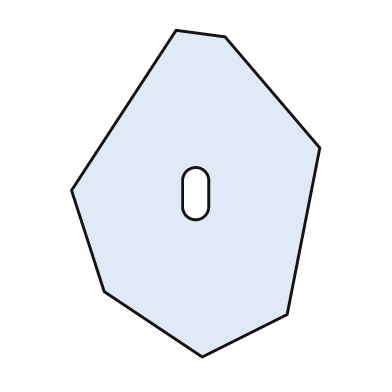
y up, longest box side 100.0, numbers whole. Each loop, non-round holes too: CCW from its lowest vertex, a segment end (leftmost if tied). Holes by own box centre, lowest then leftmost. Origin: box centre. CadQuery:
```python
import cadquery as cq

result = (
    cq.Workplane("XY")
    .moveTo(2.0, -50.0)
    .lineTo(28.0, -37.0)
    .lineTo(38.0, 14.0)
    .lineTo(9.0, 48.0)
    .lineTo(-6.0, 50.0)
    .lineTo(-38.0, 1.0)
    .lineTo(-28.0, -30.0)
    .close()
    .moveTo(-4.0, -4.0)
    .threePointArc((0.0, -8.0), (4.0, -4.0))
    .lineTo(4.0, 4.0)
    .threePointArc((0.0, 8.0), (-4.0, 4.0))
    .close()
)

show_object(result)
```